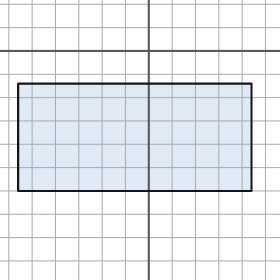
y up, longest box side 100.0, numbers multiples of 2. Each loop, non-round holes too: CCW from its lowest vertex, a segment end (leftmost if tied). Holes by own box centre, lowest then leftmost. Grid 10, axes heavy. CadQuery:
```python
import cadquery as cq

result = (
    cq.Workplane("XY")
    .moveTo(-56.0, -60.0)
    .lineTo(44.0, -60.0)
    .lineTo(44.0, -14.0)
    .lineTo(-56.0, -14.0)
    .close()
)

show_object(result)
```